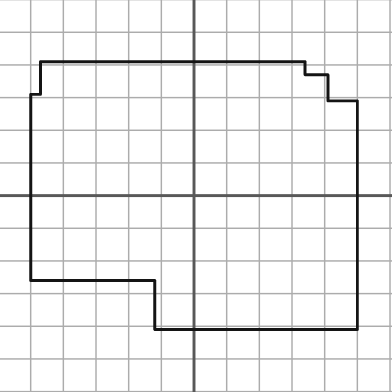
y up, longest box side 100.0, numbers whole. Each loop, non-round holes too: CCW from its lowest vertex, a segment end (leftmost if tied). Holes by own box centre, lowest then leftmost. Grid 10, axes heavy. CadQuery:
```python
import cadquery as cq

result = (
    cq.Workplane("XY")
    .moveTo(-12.0, -41.0)
    .lineTo(50.0, -41.0)
    .lineTo(50.0, 29.0)
    .lineTo(41.0, 29.0)
    .lineTo(41.0, 37.0)
    .lineTo(34.0, 37.0)
    .lineTo(34.0, 41.0)
    .lineTo(-47.0, 41.0)
    .lineTo(-47.0, 31.0)
    .lineTo(-50.0, 31.0)
    .lineTo(-50.0, -26.0)
    .lineTo(-12.0, -26.0)
    .close()
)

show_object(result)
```